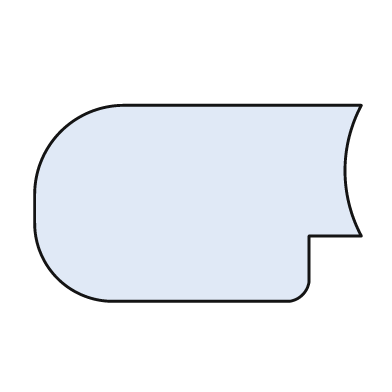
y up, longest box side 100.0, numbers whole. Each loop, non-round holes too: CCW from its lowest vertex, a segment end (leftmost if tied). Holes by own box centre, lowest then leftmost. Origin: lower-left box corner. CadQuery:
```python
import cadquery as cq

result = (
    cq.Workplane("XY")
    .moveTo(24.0, 0.0)
    .lineTo(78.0, 0.0)
    .threePointArc((82.0, 2.0), (84.0, 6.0))
    .lineTo(84.0, 20.0)
    .lineTo(100.0, 20.0)
    .threePointArc((95.0, 40.0), (100.0, 60.0))
    .lineTo(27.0, 60.0)
    .threePointArc((8.0, 52.0), (0.0, 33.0))
    .lineTo(0.0, 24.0)
    .threePointArc((7.0, 7.0), (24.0, 0.0))
    .close()
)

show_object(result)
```